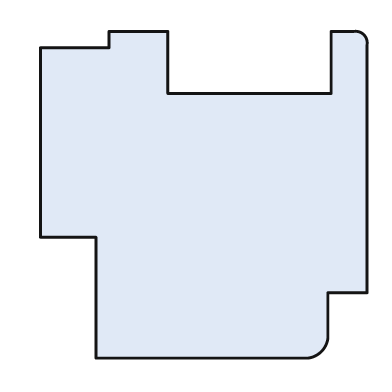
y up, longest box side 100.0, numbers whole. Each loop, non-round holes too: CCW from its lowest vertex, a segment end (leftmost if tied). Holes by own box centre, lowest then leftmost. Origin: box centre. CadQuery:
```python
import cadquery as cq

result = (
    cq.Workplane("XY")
    .moveTo(-33.0, -50.0)
    .lineTo(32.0, -50.0)
    .threePointArc((36.0, -48.0), (38.0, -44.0))
    .lineTo(38.0, -30.0)
    .lineTo(50.0, -30.0)
    .lineTo(50.0, 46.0)
    .threePointArc((49.0, 49.0), (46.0, 50.0))
    .lineTo(39.0, 50.0)
    .lineTo(39.0, 31.0)
    .lineTo(-11.0, 31.0)
    .lineTo(-11.0, 50.0)
    .lineTo(-29.0, 50.0)
    .lineTo(-29.0, 45.0)
    .lineTo(-50.0, 45.0)
    .lineTo(-50.0, -13.0)
    .lineTo(-33.0, -13.0)
    .close()
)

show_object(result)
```